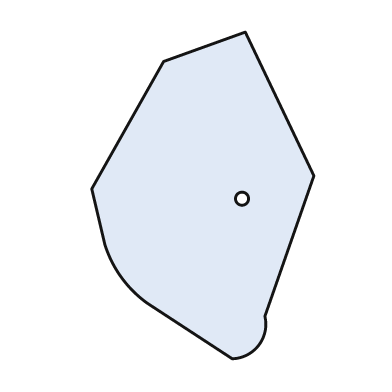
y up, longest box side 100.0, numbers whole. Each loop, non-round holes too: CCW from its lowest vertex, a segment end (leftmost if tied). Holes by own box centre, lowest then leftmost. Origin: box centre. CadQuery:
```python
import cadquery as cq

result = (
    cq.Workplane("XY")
    .moveTo(9.0, -50.0)
    .threePointArc((17.0, -46.0), (19.0, -37.0))
    .lineTo(34.0, 6.0)
    .lineTo(13.0, 50.0)
    .lineTo(-12.0, 41.0)
    .lineTo(-34.0, 2.0)
    .lineTo(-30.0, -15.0)
    .threePointArc((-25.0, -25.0), (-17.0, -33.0))
    .close()
    .moveTo(12.0, -1.0)
    .circle(2.0)
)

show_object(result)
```